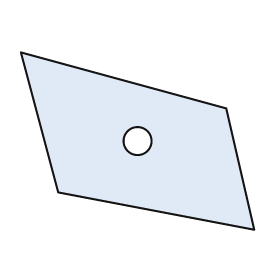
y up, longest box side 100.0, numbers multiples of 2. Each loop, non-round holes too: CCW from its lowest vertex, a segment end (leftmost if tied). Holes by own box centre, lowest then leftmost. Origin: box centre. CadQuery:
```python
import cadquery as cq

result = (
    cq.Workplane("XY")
    .moveTo(50.0, -38.0)
    .lineTo(38.0, 14.0)
    .lineTo(-50.0, 38.0)
    .lineTo(-34.0, -22.0)
    .close()
    .moveTo(0.0, 0.0)
    .circle(6.0)
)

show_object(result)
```